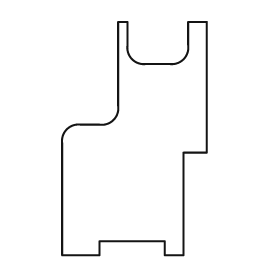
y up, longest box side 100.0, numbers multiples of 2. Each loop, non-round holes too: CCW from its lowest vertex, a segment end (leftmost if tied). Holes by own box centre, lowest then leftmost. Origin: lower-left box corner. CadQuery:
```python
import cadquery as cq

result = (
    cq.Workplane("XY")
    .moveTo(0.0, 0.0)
    .lineTo(16.0, 0.0)
    .lineTo(16.0, 6.0)
    .lineTo(44.0, 6.0)
    .lineTo(44.0, 0.0)
    .lineTo(52.0, 0.0)
    .lineTo(52.0, 44.0)
    .lineTo(62.0, 44.0)
    .lineTo(62.0, 100.0)
    .lineTo(54.0, 100.0)
    .lineTo(54.0, 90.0)
    .threePointArc((52.0, 84.0), (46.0, 82.0))
    .lineTo(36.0, 82.0)
    .threePointArc((30.0, 84.0), (28.0, 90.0))
    .lineTo(28.0, 100.0)
    .lineTo(24.0, 100.0)
    .lineTo(24.0, 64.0)
    .threePointArc((22.0, 58.0), (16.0, 56.0))
    .lineTo(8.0, 56.0)
    .threePointArc((2.0, 54.0), (0.0, 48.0))
    .close()
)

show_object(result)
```